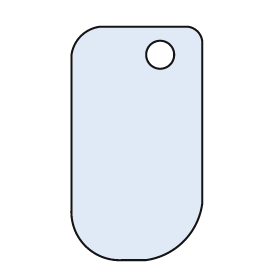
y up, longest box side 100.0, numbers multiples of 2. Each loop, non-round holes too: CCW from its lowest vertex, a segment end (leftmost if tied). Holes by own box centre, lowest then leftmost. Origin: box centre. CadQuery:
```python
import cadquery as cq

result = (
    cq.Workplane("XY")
    .moveTo(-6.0, -50.0)
    .lineTo(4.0, -50.0)
    .threePointArc((20.0, -42.0), (28.0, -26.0))
    .lineTo(28.0, 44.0)
    .threePointArc((26.0, 48.0), (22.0, 50.0))
    .lineTo(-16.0, 50.0)
    .threePointArc((-24.0, 46.0), (-28.0, 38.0))
    .lineTo(-28.0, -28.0)
    .threePointArc((-22.0, -44.0), (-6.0, -50.0))
    .close()
    .moveTo(10.0, 38.0)
    .circle(6.0)
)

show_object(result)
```